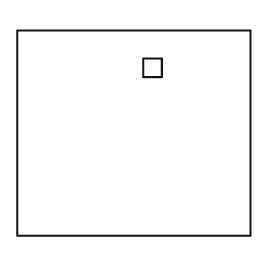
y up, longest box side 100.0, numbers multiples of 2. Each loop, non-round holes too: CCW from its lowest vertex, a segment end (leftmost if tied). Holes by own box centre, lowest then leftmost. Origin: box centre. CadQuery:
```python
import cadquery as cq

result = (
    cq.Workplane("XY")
    .moveTo(-50.0, -44.0)
    .lineTo(50.0, -44.0)
    .lineTo(50.0, 44.0)
    .lineTo(-50.0, 44.0)
    .close()
    .moveTo(4.0, 24.0)
    .lineTo(12.0, 24.0)
    .lineTo(12.0, 32.0)
    .lineTo(4.0, 32.0)
    .close()
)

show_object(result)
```